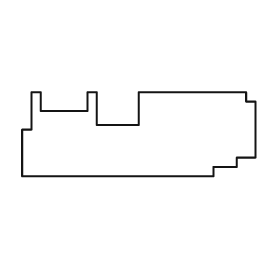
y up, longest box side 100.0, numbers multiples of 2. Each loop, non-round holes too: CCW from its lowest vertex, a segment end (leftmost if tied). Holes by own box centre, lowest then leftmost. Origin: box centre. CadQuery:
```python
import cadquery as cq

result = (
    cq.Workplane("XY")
    .moveTo(-50.0, -18.0)
    .lineTo(32.0, -18.0)
    .lineTo(32.0, -14.0)
    .lineTo(42.0, -14.0)
    .lineTo(42.0, -10.0)
    .lineTo(50.0, -10.0)
    .lineTo(50.0, 14.0)
    .lineTo(46.0, 14.0)
    .lineTo(46.0, 18.0)
    .lineTo(0.0, 18.0)
    .lineTo(0.0, 4.0)
    .lineTo(-18.0, 4.0)
    .lineTo(-18.0, 18.0)
    .lineTo(-22.0, 18.0)
    .lineTo(-22.0, 10.0)
    .lineTo(-42.0, 10.0)
    .lineTo(-42.0, 18.0)
    .lineTo(-46.0, 18.0)
    .lineTo(-46.0, 2.0)
    .lineTo(-50.0, 2.0)
    .close()
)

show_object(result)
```